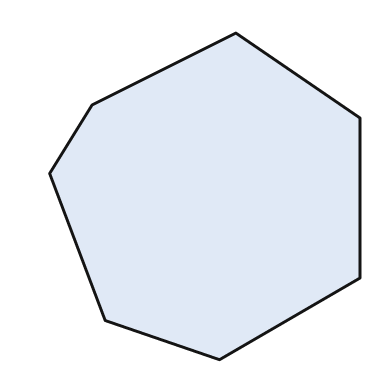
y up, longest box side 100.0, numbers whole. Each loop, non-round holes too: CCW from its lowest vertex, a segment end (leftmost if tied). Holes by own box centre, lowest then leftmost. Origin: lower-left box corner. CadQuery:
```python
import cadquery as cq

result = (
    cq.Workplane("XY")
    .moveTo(52.0, 0.0)
    .lineTo(95.0, 25.0)
    .lineTo(95.0, 74.0)
    .lineTo(57.0, 100.0)
    .lineTo(13.0, 78.0)
    .lineTo(0.0, 57.0)
    .lineTo(17.0, 12.0)
    .close()
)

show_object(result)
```